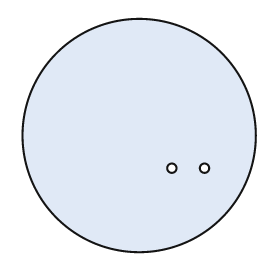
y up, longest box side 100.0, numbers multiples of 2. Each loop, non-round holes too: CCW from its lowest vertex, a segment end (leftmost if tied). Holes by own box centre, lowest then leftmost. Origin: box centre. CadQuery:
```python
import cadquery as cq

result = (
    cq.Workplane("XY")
    .moveTo(0.0, 0.0)
    .circle(50.0)
    .moveTo(14.0, -14.0)
    .circle(2.0)
    .moveTo(28.0, -14.0)
    .circle(2.0)
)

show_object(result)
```